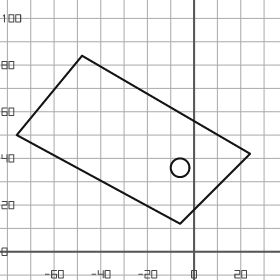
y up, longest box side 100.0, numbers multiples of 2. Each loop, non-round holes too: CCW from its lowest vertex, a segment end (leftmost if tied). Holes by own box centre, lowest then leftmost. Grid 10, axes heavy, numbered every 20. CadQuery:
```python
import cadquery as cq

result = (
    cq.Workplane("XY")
    .moveTo(-6.0, 12.0)
    .lineTo(24.0, 42.0)
    .lineTo(-48.0, 84.0)
    .lineTo(-76.0, 50.0)
    .close()
    .moveTo(-6.0, 36.0)
    .circle(4.0)
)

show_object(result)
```